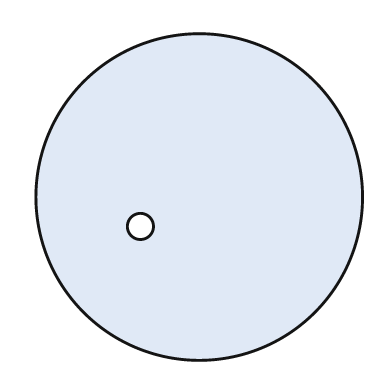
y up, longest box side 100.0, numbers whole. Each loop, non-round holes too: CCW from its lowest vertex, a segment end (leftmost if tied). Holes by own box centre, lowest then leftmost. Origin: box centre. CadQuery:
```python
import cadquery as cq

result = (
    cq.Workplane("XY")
    .moveTo(0.0, 0.0)
    .circle(50.0)
    .moveTo(-18.0, -9.0)
    .circle(4.0)
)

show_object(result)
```